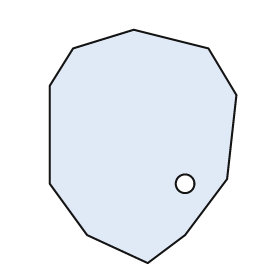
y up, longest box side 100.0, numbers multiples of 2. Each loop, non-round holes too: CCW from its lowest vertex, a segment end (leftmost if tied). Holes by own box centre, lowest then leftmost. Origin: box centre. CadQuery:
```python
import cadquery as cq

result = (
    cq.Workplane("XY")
    .moveTo(2.0, -50.0)
    .lineTo(18.0, -38.0)
    .lineTo(36.0, -14.0)
    .lineTo(40.0, 22.0)
    .lineTo(28.0, 42.0)
    .lineTo(-4.0, 50.0)
    .lineTo(-30.0, 42.0)
    .lineTo(-40.0, 26.0)
    .lineTo(-40.0, -16.0)
    .lineTo(-24.0, -38.0)
    .close()
    .moveTo(18.0, -16.0)
    .circle(4.0)
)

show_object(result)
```